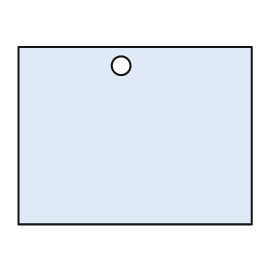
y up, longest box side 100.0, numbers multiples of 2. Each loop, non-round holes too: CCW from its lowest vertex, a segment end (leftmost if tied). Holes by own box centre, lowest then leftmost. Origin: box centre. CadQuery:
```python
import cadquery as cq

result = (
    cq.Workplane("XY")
    .moveTo(-50.0, -38.0)
    .lineTo(50.0, -38.0)
    .lineTo(50.0, 38.0)
    .lineTo(-50.0, 38.0)
    .close()
    .moveTo(-6.0, 30.0)
    .circle(4.0)
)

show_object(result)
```